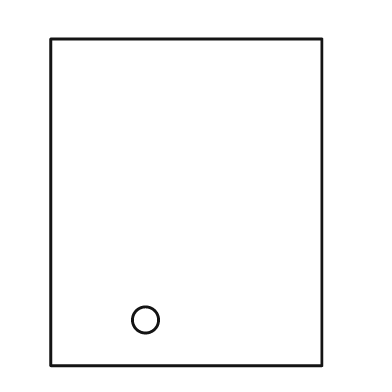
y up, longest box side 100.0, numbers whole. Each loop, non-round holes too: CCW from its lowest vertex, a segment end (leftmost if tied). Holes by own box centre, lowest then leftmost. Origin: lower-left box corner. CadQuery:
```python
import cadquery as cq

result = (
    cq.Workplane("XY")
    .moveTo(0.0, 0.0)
    .lineTo(83.0, 0.0)
    .lineTo(83.0, 100.0)
    .lineTo(0.0, 100.0)
    .close()
    .moveTo(29.0, 14.0)
    .circle(4.0)
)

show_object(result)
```